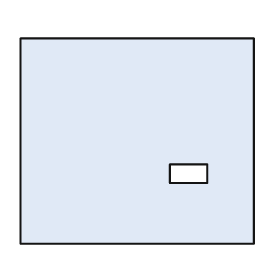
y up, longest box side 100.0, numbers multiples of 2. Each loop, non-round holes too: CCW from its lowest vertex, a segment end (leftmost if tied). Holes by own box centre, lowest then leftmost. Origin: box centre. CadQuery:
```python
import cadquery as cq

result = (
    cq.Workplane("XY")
    .moveTo(-50.0, -44.0)
    .lineTo(50.0, -44.0)
    .lineTo(50.0, 44.0)
    .lineTo(-50.0, 44.0)
    .close()
    .moveTo(14.0, -18.0)
    .lineTo(30.0, -18.0)
    .lineTo(30.0, -10.0)
    .lineTo(14.0, -10.0)
    .close()
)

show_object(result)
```